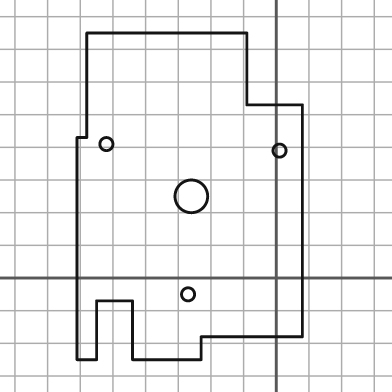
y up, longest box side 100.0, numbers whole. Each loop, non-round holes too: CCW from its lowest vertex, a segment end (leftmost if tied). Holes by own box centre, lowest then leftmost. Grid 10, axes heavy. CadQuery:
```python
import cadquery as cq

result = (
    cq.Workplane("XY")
    .moveTo(-61.0, -25.0)
    .lineTo(-55.0, -25.0)
    .lineTo(-55.0, -7.0)
    .lineTo(-44.0, -7.0)
    .lineTo(-44.0, -25.0)
    .lineTo(-23.0, -25.0)
    .lineTo(-23.0, -18.0)
    .lineTo(8.0, -18.0)
    .lineTo(8.0, 53.0)
    .lineTo(-9.0, 53.0)
    .lineTo(-9.0, 75.0)
    .lineTo(-58.0, 75.0)
    .lineTo(-58.0, 43.0)
    .lineTo(-61.0, 43.0)
    .close()
    .moveTo(-27.0, -5.0)
    .circle(2.0)
    .moveTo(-26.0, 25.0)
    .circle(5.0)
    .moveTo(1.0, 39.0)
    .circle(2.0)
    .moveTo(-52.0, 41.0)
    .circle(2.0)
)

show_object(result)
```